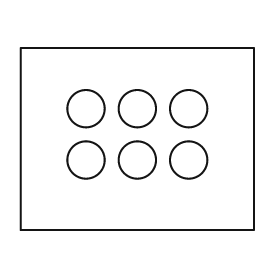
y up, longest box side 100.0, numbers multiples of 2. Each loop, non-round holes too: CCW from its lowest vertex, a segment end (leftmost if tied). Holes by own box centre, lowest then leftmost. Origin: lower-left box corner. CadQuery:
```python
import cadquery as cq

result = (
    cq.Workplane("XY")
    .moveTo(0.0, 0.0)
    .lineTo(100.0, 0.0)
    .lineTo(100.0, 78.0)
    .lineTo(0.0, 78.0)
    .close()
    .moveTo(28.0, 30.0)
    .circle(8.0)
    .moveTo(50.0, 30.0)
    .circle(8.0)
    .moveTo(72.0, 30.0)
    .circle(8.0)
    .moveTo(28.0, 52.0)
    .circle(8.0)
    .moveTo(50.0, 52.0)
    .circle(8.0)
    .moveTo(72.0, 52.0)
    .circle(8.0)
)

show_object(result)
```